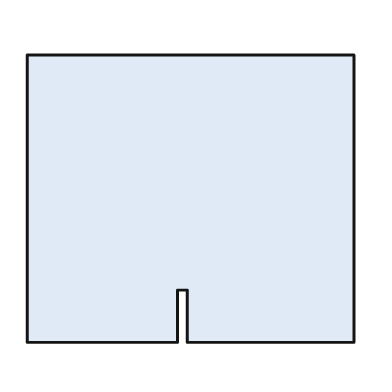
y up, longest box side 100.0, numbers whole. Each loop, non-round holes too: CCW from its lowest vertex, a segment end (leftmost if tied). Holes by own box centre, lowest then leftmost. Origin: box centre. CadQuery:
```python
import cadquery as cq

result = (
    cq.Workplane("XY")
    .moveTo(-50.0, -44.0)
    .lineTo(-4.0, -44.0)
    .lineTo(-4.0, -28.0)
    .lineTo(-1.0, -28.0)
    .lineTo(-1.0, -44.0)
    .lineTo(50.0, -44.0)
    .lineTo(50.0, 44.0)
    .lineTo(-50.0, 44.0)
    .close()
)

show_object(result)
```